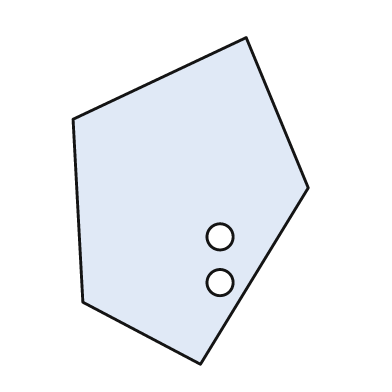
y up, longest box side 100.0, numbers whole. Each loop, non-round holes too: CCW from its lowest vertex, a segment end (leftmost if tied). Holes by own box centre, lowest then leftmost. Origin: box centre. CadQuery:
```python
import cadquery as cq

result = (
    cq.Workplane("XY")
    .moveTo(3.0, -50.0)
    .lineTo(36.0, 4.0)
    .lineTo(17.0, 50.0)
    .lineTo(-36.0, 25.0)
    .lineTo(-33.0, -31.0)
    .close()
    .moveTo(9.0, -25.0)
    .circle(4.0)
    .moveTo(9.0, -11.0)
    .circle(4.0)
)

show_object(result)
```